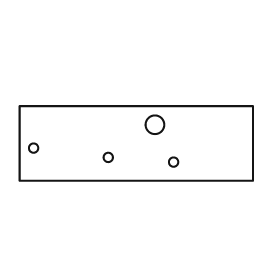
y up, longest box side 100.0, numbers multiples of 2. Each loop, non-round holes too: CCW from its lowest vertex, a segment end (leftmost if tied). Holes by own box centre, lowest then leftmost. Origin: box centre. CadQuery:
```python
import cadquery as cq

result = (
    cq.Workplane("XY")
    .moveTo(-50.0, -16.0)
    .lineTo(50.0, -16.0)
    .lineTo(50.0, 16.0)
    .lineTo(-50.0, 16.0)
    .close()
    .moveTo(16.0, -8.0)
    .circle(2.0)
    .moveTo(-12.0, -6.0)
    .circle(2.0)
    .moveTo(-44.0, -2.0)
    .circle(2.0)
    .moveTo(8.0, 8.0)
    .circle(4.0)
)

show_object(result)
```